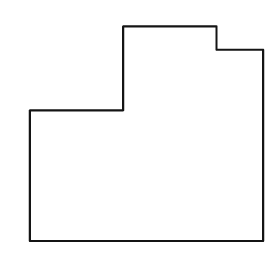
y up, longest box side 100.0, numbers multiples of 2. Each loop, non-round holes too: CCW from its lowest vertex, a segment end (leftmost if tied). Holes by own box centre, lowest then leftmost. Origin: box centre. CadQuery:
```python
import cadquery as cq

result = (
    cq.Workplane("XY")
    .moveTo(-50.0, -46.0)
    .lineTo(50.0, -46.0)
    .lineTo(50.0, 36.0)
    .lineTo(30.0, 36.0)
    .lineTo(30.0, 46.0)
    .lineTo(-10.0, 46.0)
    .lineTo(-10.0, 10.0)
    .lineTo(-50.0, 10.0)
    .close()
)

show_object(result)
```